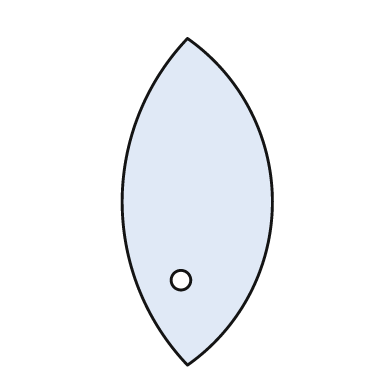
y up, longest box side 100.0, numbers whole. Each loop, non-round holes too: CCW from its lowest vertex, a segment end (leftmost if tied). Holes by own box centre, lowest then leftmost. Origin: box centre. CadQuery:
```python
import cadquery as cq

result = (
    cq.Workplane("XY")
    .moveTo(-3.0, -50.0)
    .threePointArc((23.0, 0.0), (-3.0, 50.0))
    .threePointArc((-23.0, 0.0), (-3.0, -50.0))
    .close()
    .moveTo(-5.0, -24.0)
    .circle(3.0)
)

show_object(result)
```